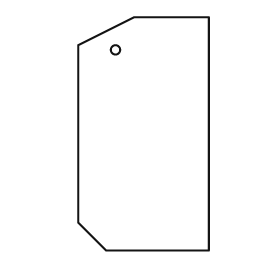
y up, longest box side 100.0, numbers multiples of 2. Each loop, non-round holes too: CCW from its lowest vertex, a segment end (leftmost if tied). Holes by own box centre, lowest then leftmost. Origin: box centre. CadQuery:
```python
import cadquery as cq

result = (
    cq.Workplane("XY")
    .moveTo(-16.0, -50.0)
    .lineTo(28.0, -50.0)
    .lineTo(28.0, 50.0)
    .lineTo(-4.0, 50.0)
    .lineTo(-28.0, 38.0)
    .lineTo(-28.0, -38.0)
    .close()
    .moveTo(-12.0, 36.0)
    .circle(2.0)
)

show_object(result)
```